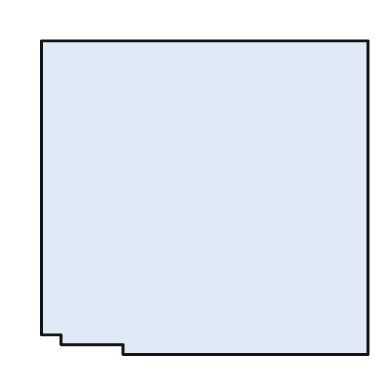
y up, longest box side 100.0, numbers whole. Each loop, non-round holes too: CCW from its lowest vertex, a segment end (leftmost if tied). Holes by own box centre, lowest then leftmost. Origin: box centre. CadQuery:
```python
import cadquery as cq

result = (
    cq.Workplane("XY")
    .moveTo(-25.0, -48.0)
    .lineTo(50.0, -48.0)
    .lineTo(50.0, 48.0)
    .lineTo(-50.0, 48.0)
    .lineTo(-50.0, -42.0)
    .lineTo(-44.0, -42.0)
    .lineTo(-44.0, -45.0)
    .lineTo(-25.0, -45.0)
    .close()
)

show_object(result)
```